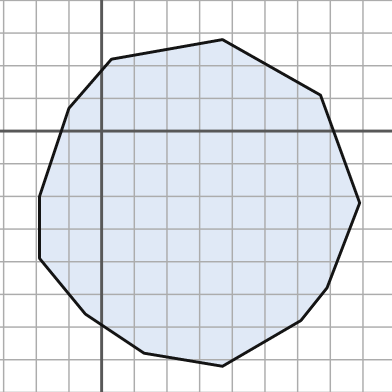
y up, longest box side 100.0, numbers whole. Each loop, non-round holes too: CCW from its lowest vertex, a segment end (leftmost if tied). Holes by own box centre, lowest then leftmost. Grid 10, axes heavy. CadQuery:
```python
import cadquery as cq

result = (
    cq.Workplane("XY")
    .moveTo(37.0, -72.0)
    .lineTo(61.0, -58.0)
    .lineTo(69.0, -48.0)
    .lineTo(79.0, -22.0)
    .lineTo(67.0, 11.0)
    .lineTo(37.0, 28.0)
    .lineTo(3.0, 22.0)
    .lineTo(-10.0, 7.0)
    .lineTo(-19.0, -20.0)
    .lineTo(-19.0, -39.0)
    .lineTo(-5.0, -56.0)
    .lineTo(13.0, -68.0)
    .close()
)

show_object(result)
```